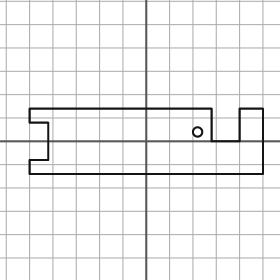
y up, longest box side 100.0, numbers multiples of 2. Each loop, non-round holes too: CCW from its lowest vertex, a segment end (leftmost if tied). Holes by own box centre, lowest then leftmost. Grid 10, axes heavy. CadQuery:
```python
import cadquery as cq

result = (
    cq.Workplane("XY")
    .moveTo(-50.0, -14.0)
    .lineTo(50.0, -14.0)
    .lineTo(50.0, 14.0)
    .lineTo(40.0, 14.0)
    .lineTo(40.0, 0.0)
    .lineTo(28.0, 0.0)
    .lineTo(28.0, 14.0)
    .lineTo(-50.0, 14.0)
    .lineTo(-50.0, 8.0)
    .lineTo(-42.0, 8.0)
    .lineTo(-42.0, -8.0)
    .lineTo(-50.0, -8.0)
    .close()
    .moveTo(22.0, 4.0)
    .circle(2.0)
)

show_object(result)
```